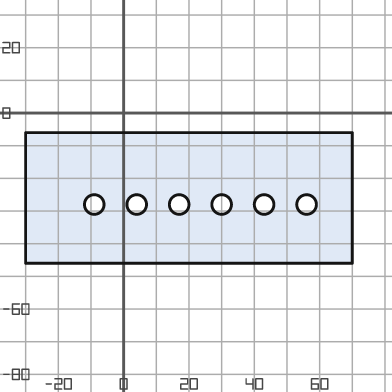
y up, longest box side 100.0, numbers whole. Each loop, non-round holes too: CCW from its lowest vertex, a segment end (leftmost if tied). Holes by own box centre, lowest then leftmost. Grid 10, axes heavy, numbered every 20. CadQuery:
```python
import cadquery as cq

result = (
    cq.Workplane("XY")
    .moveTo(-30.0, -46.0)
    .lineTo(70.0, -46.0)
    .lineTo(70.0, -6.0)
    .lineTo(-30.0, -6.0)
    .close()
    .moveTo(-9.0, -28.0)
    .circle(3.0)
    .moveTo(4.0, -28.0)
    .circle(3.0)
    .moveTo(17.0, -28.0)
    .circle(3.0)
    .moveTo(30.0, -28.0)
    .circle(3.0)
    .moveTo(43.0, -28.0)
    .circle(3.0)
    .moveTo(56.0, -28.0)
    .circle(3.0)
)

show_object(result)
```